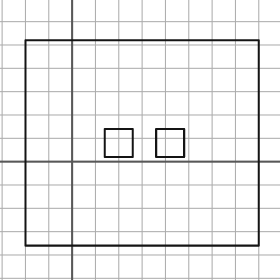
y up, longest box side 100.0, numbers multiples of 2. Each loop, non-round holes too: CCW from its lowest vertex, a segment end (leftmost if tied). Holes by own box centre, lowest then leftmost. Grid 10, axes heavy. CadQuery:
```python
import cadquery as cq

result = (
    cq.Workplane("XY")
    .moveTo(-20.0, -36.0)
    .lineTo(80.0, -36.0)
    .lineTo(80.0, 52.0)
    .lineTo(-20.0, 52.0)
    .close()
    .moveTo(14.0, 2.0)
    .lineTo(26.0, 2.0)
    .lineTo(26.0, 14.0)
    .lineTo(14.0, 14.0)
    .close()
    .moveTo(36.0, 2.0)
    .lineTo(48.0, 2.0)
    .lineTo(48.0, 14.0)
    .lineTo(36.0, 14.0)
    .close()
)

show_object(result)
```